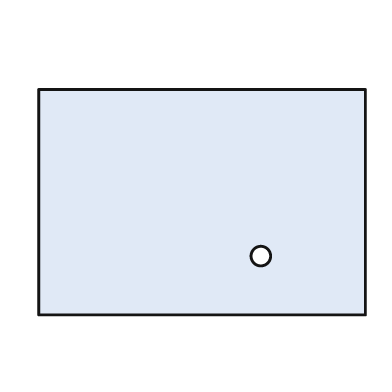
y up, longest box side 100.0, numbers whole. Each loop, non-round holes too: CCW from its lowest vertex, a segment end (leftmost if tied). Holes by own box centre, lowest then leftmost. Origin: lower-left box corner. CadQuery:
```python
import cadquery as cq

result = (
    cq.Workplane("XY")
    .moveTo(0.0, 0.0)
    .lineTo(100.0, 0.0)
    .lineTo(100.0, 69.0)
    .lineTo(0.0, 69.0)
    .close()
    .moveTo(68.0, 18.0)
    .circle(3.0)
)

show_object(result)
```